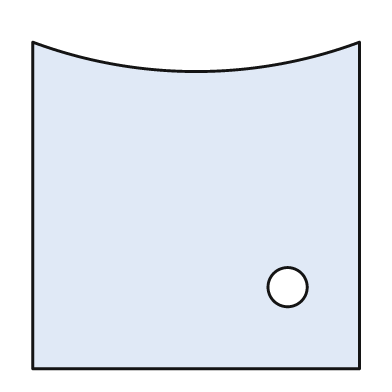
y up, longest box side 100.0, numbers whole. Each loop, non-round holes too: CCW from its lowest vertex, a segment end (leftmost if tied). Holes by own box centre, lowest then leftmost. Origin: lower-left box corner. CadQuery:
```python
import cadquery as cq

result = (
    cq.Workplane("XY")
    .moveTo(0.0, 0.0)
    .lineTo(100.0, 0.0)
    .lineTo(100.0, 100.0)
    .threePointArc((50.0, 91.0), (0.0, 100.0))
    .close()
    .moveTo(78.0, 25.0)
    .circle(6.0)
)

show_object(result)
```